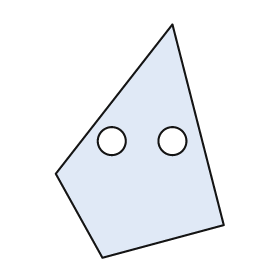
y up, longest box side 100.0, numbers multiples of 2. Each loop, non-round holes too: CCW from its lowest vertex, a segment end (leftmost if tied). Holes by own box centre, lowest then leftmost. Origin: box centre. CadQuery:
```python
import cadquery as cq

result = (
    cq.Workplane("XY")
    .moveTo(-16.0, -50.0)
    .lineTo(36.0, -36.0)
    .lineTo(14.0, 50.0)
    .lineTo(-36.0, -14.0)
    .close()
    .moveTo(-12.0, 0.0)
    .circle(6.0)
    .moveTo(14.0, 0.0)
    .circle(6.0)
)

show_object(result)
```